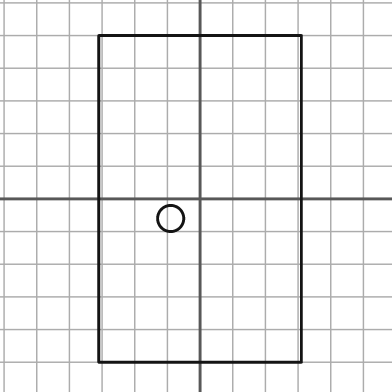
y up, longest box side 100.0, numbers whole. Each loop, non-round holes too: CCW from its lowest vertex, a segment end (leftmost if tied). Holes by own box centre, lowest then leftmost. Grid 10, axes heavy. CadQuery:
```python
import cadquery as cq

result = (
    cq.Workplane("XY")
    .moveTo(-31.0, -50.0)
    .lineTo(31.0, -50.0)
    .lineTo(31.0, 50.0)
    .lineTo(-31.0, 50.0)
    .close()
    .moveTo(-9.0, -6.0)
    .circle(4.0)
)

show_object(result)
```